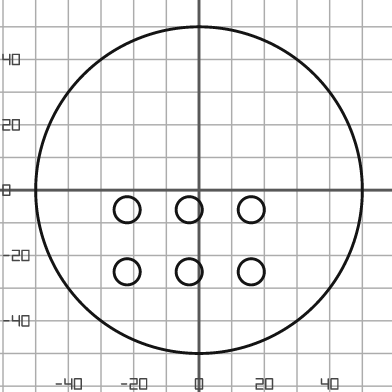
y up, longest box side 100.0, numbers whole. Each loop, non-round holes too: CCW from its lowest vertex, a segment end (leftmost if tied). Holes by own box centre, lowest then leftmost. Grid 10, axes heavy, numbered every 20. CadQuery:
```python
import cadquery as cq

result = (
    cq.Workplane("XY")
    .moveTo(0.0, 0.0)
    .circle(50.0)
    .moveTo(-22.0, -25.0)
    .circle(4.0)
    .moveTo(-3.0, -25.0)
    .circle(4.0)
    .moveTo(16.0, -25.0)
    .circle(4.0)
    .moveTo(-22.0, -6.0)
    .circle(4.0)
    .moveTo(-3.0, -6.0)
    .circle(4.0)
    .moveTo(16.0, -6.0)
    .circle(4.0)
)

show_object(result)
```